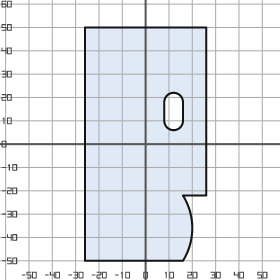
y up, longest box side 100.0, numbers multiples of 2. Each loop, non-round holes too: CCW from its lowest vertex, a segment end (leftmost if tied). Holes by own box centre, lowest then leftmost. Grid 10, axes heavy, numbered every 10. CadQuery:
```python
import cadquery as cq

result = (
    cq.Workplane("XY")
    .moveTo(-26.0, -50.0)
    .lineTo(16.0, -50.0)
    .threePointArc((20.0, -36.0), (16.0, -22.0))
    .lineTo(26.0, -22.0)
    .lineTo(26.0, 50.0)
    .lineTo(-26.0, 50.0)
    .close()
    .moveTo(8.0, 10.0)
    .threePointArc((12.0, 6.0), (16.0, 10.0))
    .lineTo(16.0, 18.0)
    .threePointArc((12.0, 22.0), (8.0, 18.0))
    .close()
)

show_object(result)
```